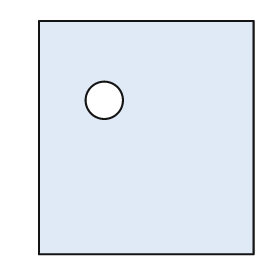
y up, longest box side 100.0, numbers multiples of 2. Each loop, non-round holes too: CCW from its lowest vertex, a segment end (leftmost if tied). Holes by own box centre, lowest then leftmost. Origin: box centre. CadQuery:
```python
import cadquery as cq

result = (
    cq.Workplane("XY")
    .moveTo(-46.0, -50.0)
    .lineTo(46.0, -50.0)
    .lineTo(46.0, 50.0)
    .lineTo(-46.0, 50.0)
    .close()
    .moveTo(-18.0, 16.0)
    .circle(8.0)
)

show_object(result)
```